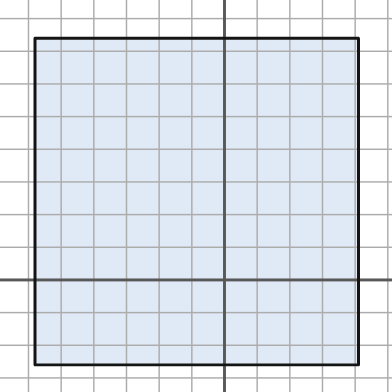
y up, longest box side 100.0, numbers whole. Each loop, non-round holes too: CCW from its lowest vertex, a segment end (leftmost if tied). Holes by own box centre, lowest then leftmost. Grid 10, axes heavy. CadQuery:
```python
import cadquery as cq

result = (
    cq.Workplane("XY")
    .moveTo(-58.0, -26.0)
    .lineTo(41.0, -26.0)
    .lineTo(41.0, 74.0)
    .lineTo(-58.0, 74.0)
    .close()
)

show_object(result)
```